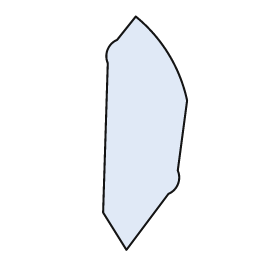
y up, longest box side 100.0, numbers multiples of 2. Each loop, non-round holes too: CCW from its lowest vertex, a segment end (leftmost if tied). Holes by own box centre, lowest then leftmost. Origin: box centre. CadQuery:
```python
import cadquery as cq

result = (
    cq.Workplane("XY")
    .moveTo(-8.0, -50.0)
    .lineTo(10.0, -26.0)
    .threePointArc((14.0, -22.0), (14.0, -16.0))
    .lineTo(18.0, 14.0)
    .threePointArc((10.0, 34.0), (-4.0, 50.0))
    .lineTo(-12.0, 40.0)
    .threePointArc((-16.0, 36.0), (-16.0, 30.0))
    .lineTo(-18.0, -34.0)
    .close()
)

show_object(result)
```